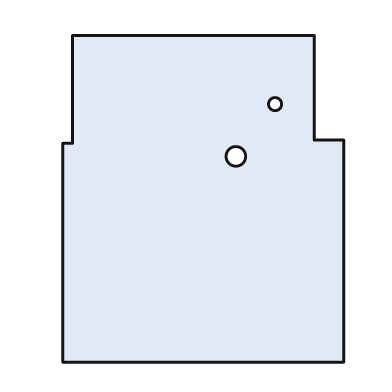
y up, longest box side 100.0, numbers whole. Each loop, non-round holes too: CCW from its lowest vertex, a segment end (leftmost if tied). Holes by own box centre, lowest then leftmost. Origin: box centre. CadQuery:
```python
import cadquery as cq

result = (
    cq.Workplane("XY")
    .moveTo(-43.0, -50.0)
    .lineTo(43.0, -50.0)
    .lineTo(43.0, 18.0)
    .lineTo(34.0, 18.0)
    .lineTo(34.0, 50.0)
    .lineTo(-40.0, 50.0)
    .lineTo(-40.0, 17.0)
    .lineTo(-43.0, 17.0)
    .close()
    .moveTo(10.0, 13.0)
    .circle(3.0)
    .moveTo(22.0, 29.0)
    .circle(2.0)
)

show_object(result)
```